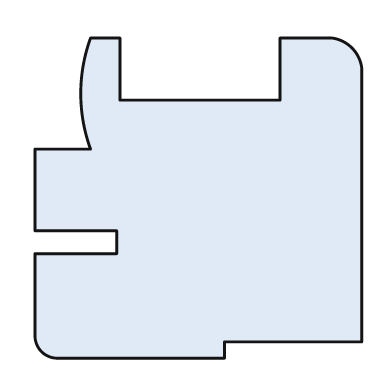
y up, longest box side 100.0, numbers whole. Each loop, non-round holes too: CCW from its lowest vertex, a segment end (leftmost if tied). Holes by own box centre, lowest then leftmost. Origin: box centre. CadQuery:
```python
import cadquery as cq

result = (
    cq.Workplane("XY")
    .moveTo(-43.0, -49.0)
    .lineTo(8.0, -49.0)
    .lineTo(8.0, -44.0)
    .lineTo(50.0, -44.0)
    .lineTo(50.0, 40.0)
    .threePointArc((47.0, 46.0), (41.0, 49.0))
    .lineTo(25.0, 49.0)
    .lineTo(25.0, 30.0)
    .lineTo(-24.0, 30.0)
    .lineTo(-24.0, 49.0)
    .lineTo(-33.0, 49.0)
    .threePointArc((-36.0, 32.0), (-33.0, 15.0))
    .lineTo(-50.0, 15.0)
    .lineTo(-50.0, -10.0)
    .lineTo(-25.0, -10.0)
    .lineTo(-25.0, -17.0)
    .lineTo(-50.0, -17.0)
    .lineTo(-50.0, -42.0)
    .threePointArc((-48.0, -47.0), (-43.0, -49.0))
    .close()
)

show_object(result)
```